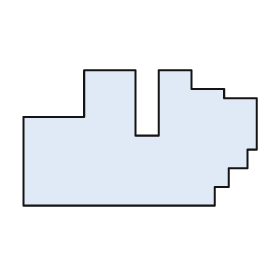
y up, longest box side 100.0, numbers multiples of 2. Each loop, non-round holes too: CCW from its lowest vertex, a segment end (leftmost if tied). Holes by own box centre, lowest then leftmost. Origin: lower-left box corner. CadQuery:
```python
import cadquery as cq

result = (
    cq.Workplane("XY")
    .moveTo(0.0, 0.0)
    .lineTo(82.0, 0.0)
    .lineTo(82.0, 8.0)
    .lineTo(88.0, 8.0)
    .lineTo(88.0, 16.0)
    .lineTo(96.0, 16.0)
    .lineTo(96.0, 24.0)
    .lineTo(100.0, 24.0)
    .lineTo(100.0, 46.0)
    .lineTo(86.0, 46.0)
    .lineTo(86.0, 50.0)
    .lineTo(72.0, 50.0)
    .lineTo(72.0, 58.0)
    .lineTo(58.0, 58.0)
    .lineTo(58.0, 30.0)
    .lineTo(48.0, 30.0)
    .lineTo(48.0, 58.0)
    .lineTo(26.0, 58.0)
    .lineTo(26.0, 38.0)
    .lineTo(0.0, 38.0)
    .close()
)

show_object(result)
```